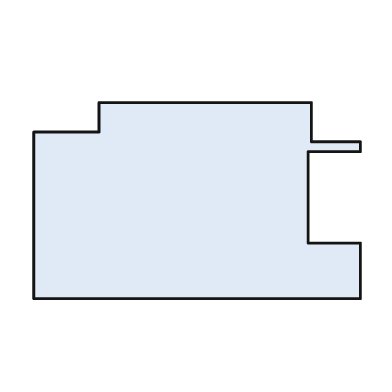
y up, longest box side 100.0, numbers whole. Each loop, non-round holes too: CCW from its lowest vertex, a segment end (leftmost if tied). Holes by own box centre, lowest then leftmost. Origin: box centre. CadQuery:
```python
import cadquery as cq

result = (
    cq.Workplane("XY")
    .moveTo(-50.0, -30.0)
    .lineTo(50.0, -30.0)
    .lineTo(50.0, -13.0)
    .lineTo(34.0, -13.0)
    .lineTo(34.0, 15.0)
    .lineTo(50.0, 15.0)
    .lineTo(50.0, 18.0)
    .lineTo(35.0, 18.0)
    .lineTo(35.0, 30.0)
    .lineTo(-30.0, 30.0)
    .lineTo(-30.0, 21.0)
    .lineTo(-50.0, 21.0)
    .close()
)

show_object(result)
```